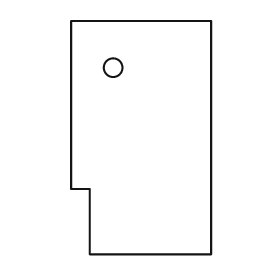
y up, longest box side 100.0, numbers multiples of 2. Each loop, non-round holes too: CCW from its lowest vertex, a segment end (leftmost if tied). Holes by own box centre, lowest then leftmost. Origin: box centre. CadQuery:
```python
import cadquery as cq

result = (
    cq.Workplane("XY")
    .moveTo(-22.0, -50.0)
    .lineTo(30.0, -50.0)
    .lineTo(30.0, 50.0)
    .lineTo(-30.0, 50.0)
    .lineTo(-30.0, -22.0)
    .lineTo(-22.0, -22.0)
    .close()
    .moveTo(-12.0, 30.0)
    .circle(4.0)
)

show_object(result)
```